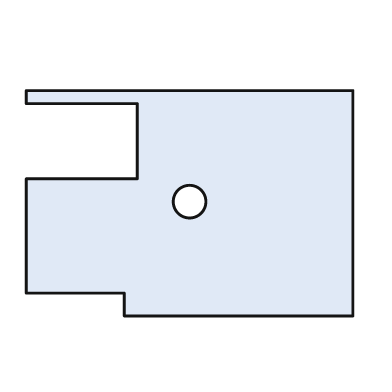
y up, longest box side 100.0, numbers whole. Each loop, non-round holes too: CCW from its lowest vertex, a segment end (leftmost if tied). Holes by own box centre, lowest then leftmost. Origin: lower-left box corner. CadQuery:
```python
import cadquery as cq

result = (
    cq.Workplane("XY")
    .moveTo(30.0, 0.0)
    .lineTo(100.0, 0.0)
    .lineTo(100.0, 69.0)
    .lineTo(0.0, 69.0)
    .lineTo(0.0, 65.0)
    .lineTo(34.0, 65.0)
    .lineTo(34.0, 42.0)
    .lineTo(0.0, 42.0)
    .lineTo(0.0, 7.0)
    .lineTo(30.0, 7.0)
    .close()
    .moveTo(50.0, 35.0)
    .circle(5.0)
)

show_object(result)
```